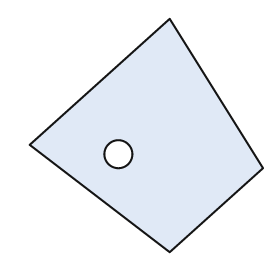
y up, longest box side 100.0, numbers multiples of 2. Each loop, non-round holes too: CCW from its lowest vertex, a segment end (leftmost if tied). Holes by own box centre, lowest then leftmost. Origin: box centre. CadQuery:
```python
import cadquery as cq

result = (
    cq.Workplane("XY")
    .moveTo(10.0, -50.0)
    .lineTo(50.0, -14.0)
    .lineTo(10.0, 50.0)
    .lineTo(-50.0, -4.0)
    .close()
    .moveTo(-12.0, -8.0)
    .circle(6.0)
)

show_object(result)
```